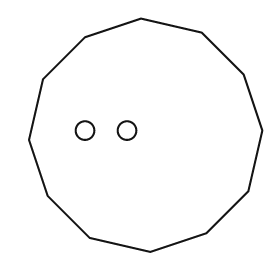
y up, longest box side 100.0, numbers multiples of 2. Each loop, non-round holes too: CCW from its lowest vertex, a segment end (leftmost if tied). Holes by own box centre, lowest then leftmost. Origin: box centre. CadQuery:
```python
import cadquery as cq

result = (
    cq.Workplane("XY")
    .moveTo(2.0, -50.0)
    .lineTo(26.0, -42.0)
    .lineTo(44.0, -24.0)
    .lineTo(50.0, 2.0)
    .lineTo(42.0, 26.0)
    .lineTo(24.0, 44.0)
    .lineTo(-2.0, 50.0)
    .lineTo(-26.0, 42.0)
    .lineTo(-44.0, 24.0)
    .lineTo(-50.0, -2.0)
    .lineTo(-42.0, -26.0)
    .lineTo(-24.0, -44.0)
    .close()
    .moveTo(-26.0, 2.0)
    .circle(4.0)
    .moveTo(-8.0, 2.0)
    .circle(4.0)
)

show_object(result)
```